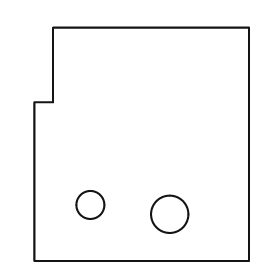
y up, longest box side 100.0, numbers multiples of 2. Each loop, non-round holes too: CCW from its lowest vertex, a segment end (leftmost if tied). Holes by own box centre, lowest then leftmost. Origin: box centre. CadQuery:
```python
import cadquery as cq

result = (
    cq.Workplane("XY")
    .moveTo(-46.0, -50.0)
    .lineTo(46.0, -50.0)
    .lineTo(46.0, 50.0)
    .lineTo(-38.0, 50.0)
    .lineTo(-38.0, 18.0)
    .lineTo(-46.0, 18.0)
    .close()
    .moveTo(12.0, -30.0)
    .circle(8.0)
    .moveTo(-22.0, -26.0)
    .circle(6.0)
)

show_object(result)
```